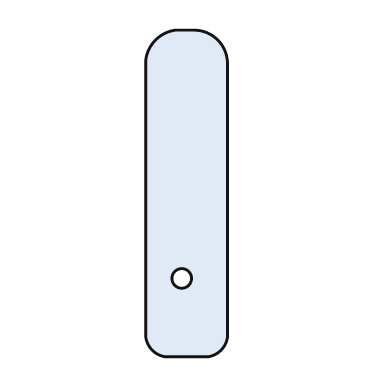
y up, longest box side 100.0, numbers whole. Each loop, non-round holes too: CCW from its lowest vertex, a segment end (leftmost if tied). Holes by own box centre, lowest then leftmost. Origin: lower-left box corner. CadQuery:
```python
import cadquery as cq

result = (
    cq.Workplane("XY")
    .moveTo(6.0, 0.0)
    .lineTo(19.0, 0.0)
    .threePointArc((23.0, 2.0), (25.0, 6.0))
    .lineTo(25.0, 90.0)
    .threePointArc((22.0, 97.0), (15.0, 100.0))
    .lineTo(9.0, 100.0)
    .threePointArc((3.0, 97.0), (0.0, 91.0))
    .lineTo(0.0, 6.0)
    .threePointArc((2.0, 2.0), (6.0, 0.0))
    .close()
    .moveTo(11.0, 24.0)
    .circle(3.0)
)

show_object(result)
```